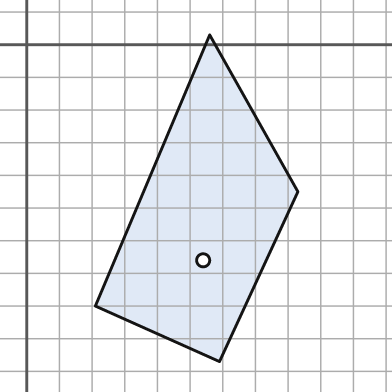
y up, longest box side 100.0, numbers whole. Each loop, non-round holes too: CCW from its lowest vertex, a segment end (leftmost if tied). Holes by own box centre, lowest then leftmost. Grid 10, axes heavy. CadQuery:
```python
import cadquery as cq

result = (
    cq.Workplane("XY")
    .moveTo(59.0, -97.0)
    .lineTo(83.0, -45.0)
    .lineTo(56.0, 3.0)
    .lineTo(21.0, -80.0)
    .close()
    .moveTo(54.0, -66.0)
    .circle(2.0)
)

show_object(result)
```